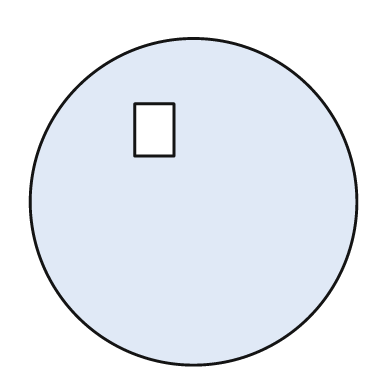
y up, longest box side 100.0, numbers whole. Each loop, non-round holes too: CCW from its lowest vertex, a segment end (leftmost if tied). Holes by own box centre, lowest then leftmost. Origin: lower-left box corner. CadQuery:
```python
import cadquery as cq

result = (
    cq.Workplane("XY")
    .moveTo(50.0, 50.0)
    .circle(50.0)
    .moveTo(32.0, 64.0)
    .lineTo(44.0, 64.0)
    .lineTo(44.0, 80.0)
    .lineTo(32.0, 80.0)
    .close()
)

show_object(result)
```